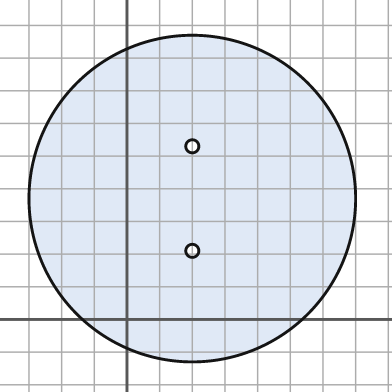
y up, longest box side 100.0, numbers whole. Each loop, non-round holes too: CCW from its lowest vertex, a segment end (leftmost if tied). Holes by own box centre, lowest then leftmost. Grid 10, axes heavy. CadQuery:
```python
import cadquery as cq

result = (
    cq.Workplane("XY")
    .moveTo(20.0, 37.0)
    .circle(50.0)
    .moveTo(20.0, 21.0)
    .circle(2.0)
    .moveTo(20.0, 53.0)
    .circle(2.0)
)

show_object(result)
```